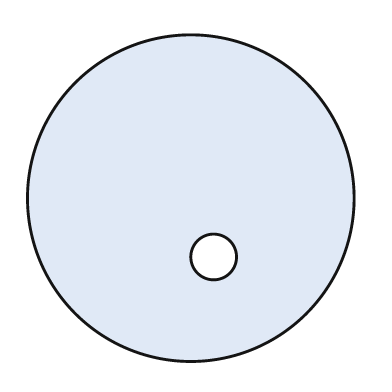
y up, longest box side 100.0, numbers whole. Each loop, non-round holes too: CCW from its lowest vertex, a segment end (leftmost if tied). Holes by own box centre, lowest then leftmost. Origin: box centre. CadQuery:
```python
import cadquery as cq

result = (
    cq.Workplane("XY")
    .moveTo(0.0, 0.0)
    .circle(50.0)
    .moveTo(7.0, -18.0)
    .circle(7.0)
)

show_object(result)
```